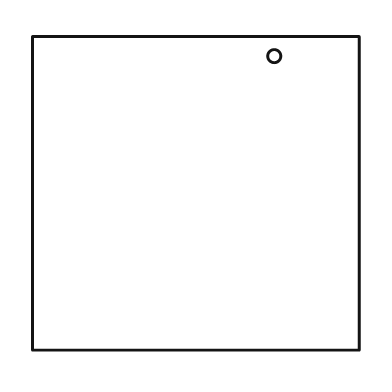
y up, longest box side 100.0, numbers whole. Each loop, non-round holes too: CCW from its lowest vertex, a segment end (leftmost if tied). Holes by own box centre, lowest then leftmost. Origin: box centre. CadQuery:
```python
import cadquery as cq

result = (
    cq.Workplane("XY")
    .moveTo(-50.0, -48.0)
    .lineTo(50.0, -48.0)
    .lineTo(50.0, 48.0)
    .lineTo(-50.0, 48.0)
    .close()
    .moveTo(24.0, 42.0)
    .circle(2.0)
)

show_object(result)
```